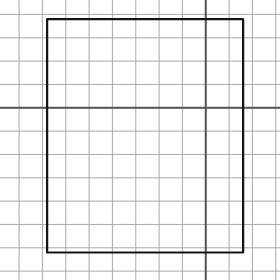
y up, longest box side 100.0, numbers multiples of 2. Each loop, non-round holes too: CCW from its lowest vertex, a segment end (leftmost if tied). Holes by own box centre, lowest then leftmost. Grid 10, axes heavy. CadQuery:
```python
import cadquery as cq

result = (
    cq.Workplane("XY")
    .moveTo(-68.0, -62.0)
    .lineTo(16.0, -62.0)
    .lineTo(16.0, 38.0)
    .lineTo(-68.0, 38.0)
    .close()
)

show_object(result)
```